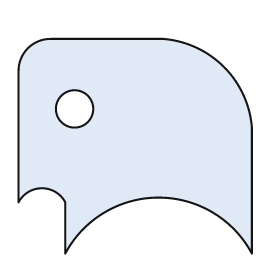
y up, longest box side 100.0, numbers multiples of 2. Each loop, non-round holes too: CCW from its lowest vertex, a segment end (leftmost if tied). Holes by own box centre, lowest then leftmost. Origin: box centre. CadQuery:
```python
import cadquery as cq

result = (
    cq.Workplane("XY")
    .moveTo(-30.0, -46.0)
    .threePointArc((10.0, -22.0), (50.0, -46.0))
    .lineTo(50.0, 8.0)
    .threePointArc((38.0, 34.0), (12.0, 46.0))
    .lineTo(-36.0, 46.0)
    .threePointArc((-46.0, 42.0), (-50.0, 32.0))
    .lineTo(-50.0, -24.0)
    .threePointArc((-40.0, -18.0), (-30.0, -24.0))
    .close()
    .moveTo(-26.0, 16.0)
    .circle(8.0)
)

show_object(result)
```